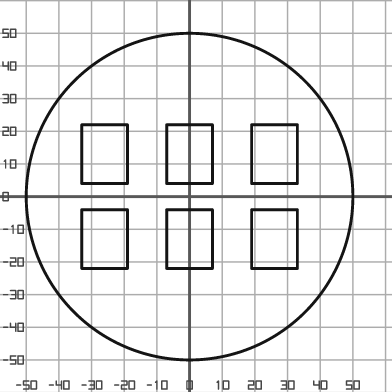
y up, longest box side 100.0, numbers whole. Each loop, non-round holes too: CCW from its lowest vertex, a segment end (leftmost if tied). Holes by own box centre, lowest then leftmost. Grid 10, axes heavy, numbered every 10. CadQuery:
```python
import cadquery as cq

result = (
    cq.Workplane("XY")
    .moveTo(0.0, 0.0)
    .circle(50.0)
    .moveTo(-33.0, -22.0)
    .lineTo(-19.0, -22.0)
    .lineTo(-19.0, -4.0)
    .lineTo(-33.0, -4.0)
    .close()
    .moveTo(-7.0, -22.0)
    .lineTo(7.0, -22.0)
    .lineTo(7.0, -4.0)
    .lineTo(-7.0, -4.0)
    .close()
    .moveTo(19.0, -22.0)
    .lineTo(33.0, -22.0)
    .lineTo(33.0, -4.0)
    .lineTo(19.0, -4.0)
    .close()
    .moveTo(-33.0, 4.0)
    .lineTo(-19.0, 4.0)
    .lineTo(-19.0, 22.0)
    .lineTo(-33.0, 22.0)
    .close()
    .moveTo(-7.0, 4.0)
    .lineTo(7.0, 4.0)
    .lineTo(7.0, 22.0)
    .lineTo(-7.0, 22.0)
    .close()
    .moveTo(19.0, 4.0)
    .lineTo(33.0, 4.0)
    .lineTo(33.0, 22.0)
    .lineTo(19.0, 22.0)
    .close()
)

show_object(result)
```